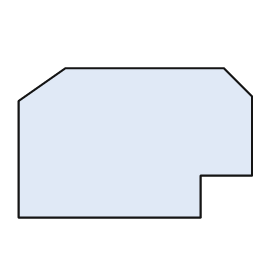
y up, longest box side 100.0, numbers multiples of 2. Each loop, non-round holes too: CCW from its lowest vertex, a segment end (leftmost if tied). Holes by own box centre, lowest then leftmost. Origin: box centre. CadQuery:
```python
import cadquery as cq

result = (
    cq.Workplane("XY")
    .moveTo(-50.0, -32.0)
    .lineTo(28.0, -32.0)
    .lineTo(28.0, -14.0)
    .lineTo(50.0, -14.0)
    .lineTo(50.0, 20.0)
    .lineTo(38.0, 32.0)
    .lineTo(-30.0, 32.0)
    .lineTo(-50.0, 18.0)
    .close()
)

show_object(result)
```